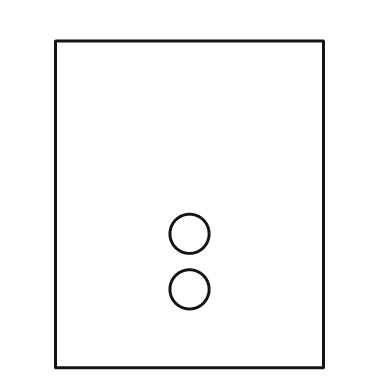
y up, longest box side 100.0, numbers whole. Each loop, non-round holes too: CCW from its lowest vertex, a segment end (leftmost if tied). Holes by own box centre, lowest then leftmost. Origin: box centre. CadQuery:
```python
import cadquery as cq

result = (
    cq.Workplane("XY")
    .moveTo(-41.0, -50.0)
    .lineTo(41.0, -50.0)
    .lineTo(41.0, 50.0)
    .lineTo(-41.0, 50.0)
    .close()
    .moveTo(0.0, -26.0)
    .circle(6.0)
    .moveTo(0.0, -9.0)
    .circle(6.0)
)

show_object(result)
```